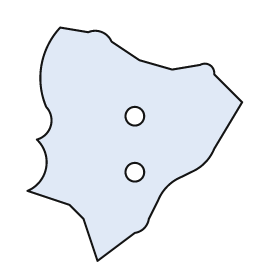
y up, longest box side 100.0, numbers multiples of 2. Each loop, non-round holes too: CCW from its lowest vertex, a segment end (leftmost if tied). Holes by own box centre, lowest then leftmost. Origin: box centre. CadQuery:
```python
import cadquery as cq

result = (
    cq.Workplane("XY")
    .moveTo(-16.0, -50.0)
    .lineTo(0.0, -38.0)
    .threePointArc((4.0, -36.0), (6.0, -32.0))
    .lineTo(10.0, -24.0)
    .threePointArc((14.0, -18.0), (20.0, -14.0))
    .lineTo(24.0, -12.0)
    .threePointArc((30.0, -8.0), (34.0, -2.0))
    .lineTo(46.0, 18.0)
    .lineTo(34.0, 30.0)
    .threePointArc((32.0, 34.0), (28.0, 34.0))
    .lineTo(16.0, 32.0)
    .lineTo(2.0, 36.0)
    .lineTo(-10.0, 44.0)
    .threePointArc((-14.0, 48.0), (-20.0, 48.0))
    .lineTo(-32.0, 50.0)
    .threePointArc((-40.0, 34.0), (-38.0, 16.0))
    .threePointArc((-36.0, 8.0), (-42.0, 2.0))
    .threePointArc((-38.0, -10.0), (-46.0, -20.0))
    .lineTo(-28.0, -26.0)
    .lineTo(-22.0, -32.0)
    .close()
    .moveTo(0.0, -12.0)
    .circle(4.0)
    .moveTo(0.0, 12.0)
    .circle(4.0)
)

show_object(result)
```